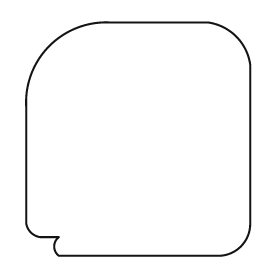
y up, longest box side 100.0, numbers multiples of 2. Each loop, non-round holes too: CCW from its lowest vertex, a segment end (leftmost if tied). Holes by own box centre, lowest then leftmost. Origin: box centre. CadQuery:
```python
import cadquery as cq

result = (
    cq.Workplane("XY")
    .moveTo(-34.0, -50.0)
    .lineTo(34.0, -50.0)
    .threePointArc((44.0, -46.0), (48.0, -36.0))
    .lineTo(48.0, 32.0)
    .threePointArc((42.0, 44.0), (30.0, 50.0))
    .lineTo(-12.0, 50.0)
    .threePointArc((-38.0, 40.0), (-48.0, 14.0))
    .lineTo(-48.0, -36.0)
    .threePointArc((-46.0, -40.0), (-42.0, -42.0))
    .lineTo(-34.0, -42.0)
    .threePointArc((-36.0, -46.0), (-34.0, -50.0))
    .close()
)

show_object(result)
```